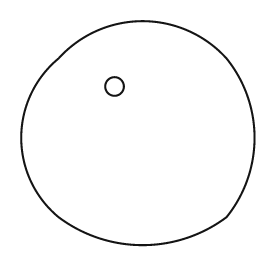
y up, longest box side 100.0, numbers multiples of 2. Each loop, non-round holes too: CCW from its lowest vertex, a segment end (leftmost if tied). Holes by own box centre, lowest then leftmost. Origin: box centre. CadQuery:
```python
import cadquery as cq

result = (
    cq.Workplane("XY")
    .moveTo(-34.0, -36.0)
    .threePointArc((2.0, -48.0), (38.0, -36.0))
    .threePointArc((50.0, -2.0), (38.0, 32.0))
    .threePointArc((2.0, 48.0), (-34.0, 32.0))
    .threePointArc((-50.0, -2.0), (-34.0, -36.0))
    .close()
    .moveTo(-10.0, 20.0)
    .circle(4.0)
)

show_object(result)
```